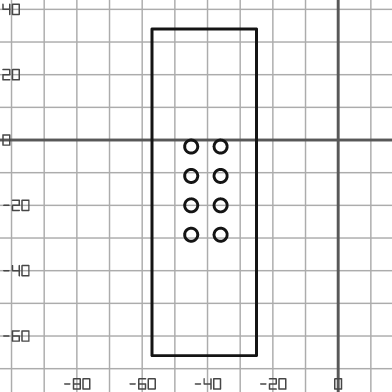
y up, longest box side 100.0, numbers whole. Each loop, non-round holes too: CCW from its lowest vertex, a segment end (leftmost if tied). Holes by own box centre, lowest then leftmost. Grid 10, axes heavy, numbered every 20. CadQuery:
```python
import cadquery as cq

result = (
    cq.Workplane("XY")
    .moveTo(-57.0, -66.0)
    .lineTo(-25.0, -66.0)
    .lineTo(-25.0, 34.0)
    .lineTo(-57.0, 34.0)
    .close()
    .moveTo(-45.0, -29.0)
    .circle(2.0)
    .moveTo(-36.0, -29.0)
    .circle(2.0)
    .moveTo(-45.0, -20.0)
    .circle(2.0)
    .moveTo(-36.0, -20.0)
    .circle(2.0)
    .moveTo(-45.0, -11.0)
    .circle(2.0)
    .moveTo(-36.0, -11.0)
    .circle(2.0)
    .moveTo(-45.0, -2.0)
    .circle(2.0)
    .moveTo(-36.0, -2.0)
    .circle(2.0)
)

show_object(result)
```